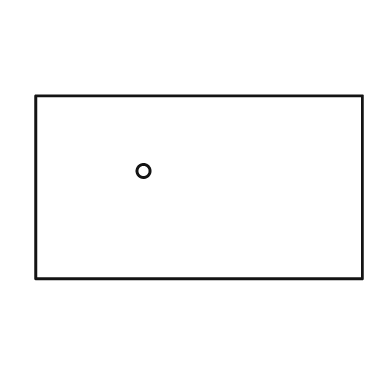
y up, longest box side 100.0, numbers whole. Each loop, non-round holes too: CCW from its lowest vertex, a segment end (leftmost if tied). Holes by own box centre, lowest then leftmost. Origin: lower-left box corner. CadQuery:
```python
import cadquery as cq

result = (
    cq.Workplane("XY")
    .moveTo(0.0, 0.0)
    .lineTo(100.0, 0.0)
    .lineTo(100.0, 56.0)
    .lineTo(0.0, 56.0)
    .close()
    .moveTo(33.0, 33.0)
    .circle(2.0)
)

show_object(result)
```